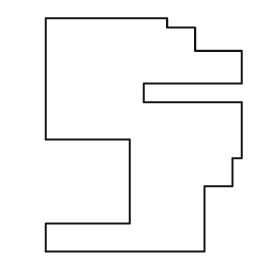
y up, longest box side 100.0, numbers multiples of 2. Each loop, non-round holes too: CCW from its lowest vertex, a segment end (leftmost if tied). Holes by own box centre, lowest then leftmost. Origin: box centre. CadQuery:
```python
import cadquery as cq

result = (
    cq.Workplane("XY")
    .moveTo(-42.0, -50.0)
    .lineTo(26.0, -50.0)
    .lineTo(26.0, -22.0)
    .lineTo(38.0, -22.0)
    .lineTo(38.0, -10.0)
    .lineTo(42.0, -10.0)
    .lineTo(42.0, 14.0)
    .lineTo(0.0, 14.0)
    .lineTo(0.0, 22.0)
    .lineTo(42.0, 22.0)
    .lineTo(42.0, 36.0)
    .lineTo(22.0, 36.0)
    .lineTo(22.0, 46.0)
    .lineTo(10.0, 46.0)
    .lineTo(10.0, 50.0)
    .lineTo(-42.0, 50.0)
    .lineTo(-42.0, -2.0)
    .lineTo(-6.0, -2.0)
    .lineTo(-6.0, -38.0)
    .lineTo(-42.0, -38.0)
    .close()
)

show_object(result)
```